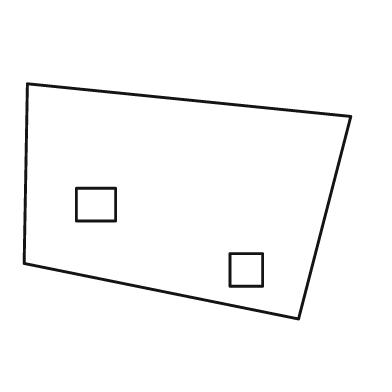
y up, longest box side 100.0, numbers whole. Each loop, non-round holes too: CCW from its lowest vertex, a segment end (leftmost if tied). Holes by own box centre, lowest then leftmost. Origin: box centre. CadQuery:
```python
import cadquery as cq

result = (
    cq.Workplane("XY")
    .moveTo(34.0, -36.0)
    .lineTo(50.0, 26.0)
    .lineTo(-49.0, 36.0)
    .lineTo(-50.0, -19.0)
    .close()
    .moveTo(13.0, -26.0)
    .lineTo(23.0, -26.0)
    .lineTo(23.0, -16.0)
    .lineTo(13.0, -16.0)
    .close()
    .moveTo(-34.0, -6.0)
    .lineTo(-22.0, -6.0)
    .lineTo(-22.0, 4.0)
    .lineTo(-34.0, 4.0)
    .close()
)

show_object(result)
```